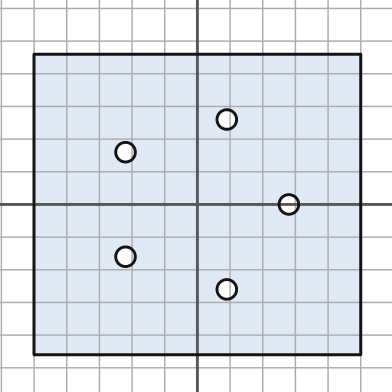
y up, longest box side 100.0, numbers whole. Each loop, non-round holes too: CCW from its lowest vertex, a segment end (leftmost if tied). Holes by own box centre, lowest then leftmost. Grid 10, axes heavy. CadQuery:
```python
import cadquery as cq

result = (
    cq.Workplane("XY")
    .moveTo(-50.0, -46.0)
    .lineTo(50.0, -46.0)
    .lineTo(50.0, 46.0)
    .lineTo(-50.0, 46.0)
    .close()
    .moveTo(9.0, -26.0)
    .circle(3.0)
    .moveTo(-22.0, -16.0)
    .circle(3.0)
    .moveTo(28.0, 0.0)
    .circle(3.0)
    .moveTo(-22.0, 16.0)
    .circle(3.0)
    .moveTo(9.0, 26.0)
    .circle(3.0)
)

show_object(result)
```